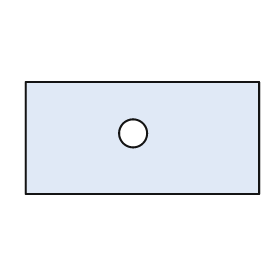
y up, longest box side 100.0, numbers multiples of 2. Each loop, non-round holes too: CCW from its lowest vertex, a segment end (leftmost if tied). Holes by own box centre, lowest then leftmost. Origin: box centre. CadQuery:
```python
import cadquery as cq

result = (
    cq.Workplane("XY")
    .moveTo(-50.0, -24.0)
    .lineTo(50.0, -24.0)
    .lineTo(50.0, 24.0)
    .lineTo(-50.0, 24.0)
    .close()
    .moveTo(-4.0, 2.0)
    .circle(6.0)
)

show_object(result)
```